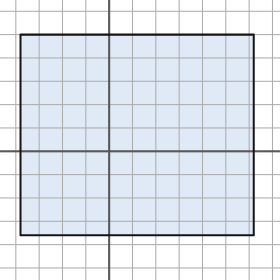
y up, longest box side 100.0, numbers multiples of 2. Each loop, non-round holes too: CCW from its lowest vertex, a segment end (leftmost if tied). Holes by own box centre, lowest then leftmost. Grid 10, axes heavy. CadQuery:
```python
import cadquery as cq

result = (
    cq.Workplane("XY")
    .moveTo(-38.0, -36.0)
    .lineTo(62.0, -36.0)
    .lineTo(62.0, 50.0)
    .lineTo(-38.0, 50.0)
    .close()
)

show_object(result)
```